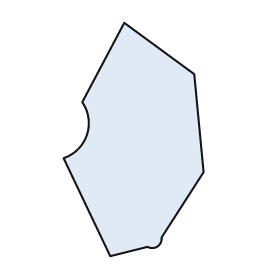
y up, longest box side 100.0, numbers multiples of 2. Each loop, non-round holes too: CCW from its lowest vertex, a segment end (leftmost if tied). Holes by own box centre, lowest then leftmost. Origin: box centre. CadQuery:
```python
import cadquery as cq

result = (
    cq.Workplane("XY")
    .moveTo(-10.0, -50.0)
    .lineTo(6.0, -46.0)
    .threePointArc((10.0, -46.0), (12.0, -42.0))
    .lineTo(30.0, -14.0)
    .lineTo(26.0, 28.0)
    .lineTo(-4.0, 50.0)
    .lineTo(-22.0, 16.0)
    .threePointArc((-20.0, 2.0), (-30.0, -8.0))
    .close()
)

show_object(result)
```